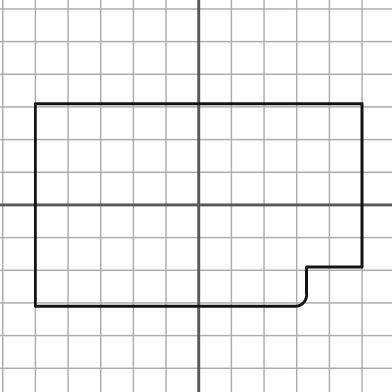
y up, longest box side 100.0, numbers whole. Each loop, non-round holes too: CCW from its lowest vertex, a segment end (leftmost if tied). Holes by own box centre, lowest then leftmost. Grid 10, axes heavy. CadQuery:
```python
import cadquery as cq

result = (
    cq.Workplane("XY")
    .moveTo(-50.0, -31.0)
    .lineTo(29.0, -31.0)
    .threePointArc((32.0, -30.0), (33.0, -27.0))
    .lineTo(33.0, -19.0)
    .lineTo(50.0, -19.0)
    .lineTo(50.0, 31.0)
    .lineTo(-50.0, 31.0)
    .close()
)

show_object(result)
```